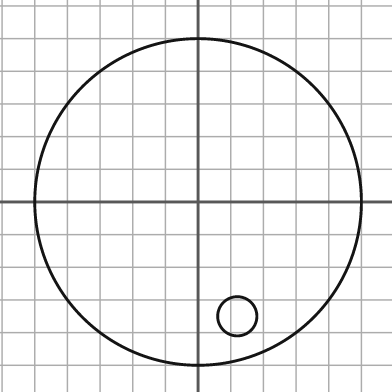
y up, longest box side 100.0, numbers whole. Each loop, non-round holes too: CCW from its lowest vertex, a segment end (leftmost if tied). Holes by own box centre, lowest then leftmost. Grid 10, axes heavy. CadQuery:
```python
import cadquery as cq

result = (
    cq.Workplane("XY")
    .moveTo(0.0, 0.0)
    .circle(50.0)
    .moveTo(12.0, -35.0)
    .circle(6.0)
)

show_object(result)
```